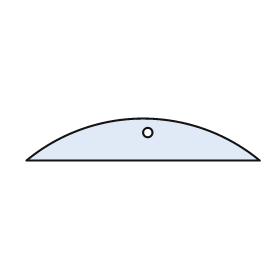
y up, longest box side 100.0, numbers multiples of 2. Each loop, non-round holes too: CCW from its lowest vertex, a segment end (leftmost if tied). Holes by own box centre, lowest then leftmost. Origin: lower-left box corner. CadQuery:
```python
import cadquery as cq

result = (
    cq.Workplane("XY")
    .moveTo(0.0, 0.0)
    .lineTo(100.0, 0.0)
    .threePointArc((50.0, 18.0), (0.0, 0.0))
    .close()
    .moveTo(52.0, 12.0)
    .circle(2.0)
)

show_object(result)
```